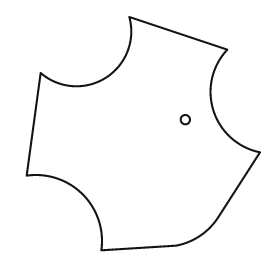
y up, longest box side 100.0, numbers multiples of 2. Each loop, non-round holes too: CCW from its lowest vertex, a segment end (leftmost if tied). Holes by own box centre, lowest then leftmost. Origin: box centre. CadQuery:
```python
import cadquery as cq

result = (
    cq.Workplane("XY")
    .moveTo(-18.0, -50.0)
    .lineTo(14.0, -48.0)
    .threePointArc((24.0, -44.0), (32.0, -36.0))
    .lineTo(50.0, -8.0)
    .threePointArc((30.0, 10.0), (36.0, 36.0))
    .lineTo(-6.0, 50.0)
    .threePointArc((-16.0, 24.0), (-44.0, 26.0))
    .lineTo(-50.0, -18.0)
    .threePointArc((-26.0, -26.0), (-18.0, -50.0))
    .close()
    .moveTo(18.0, 6.0)
    .circle(2.0)
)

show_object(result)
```